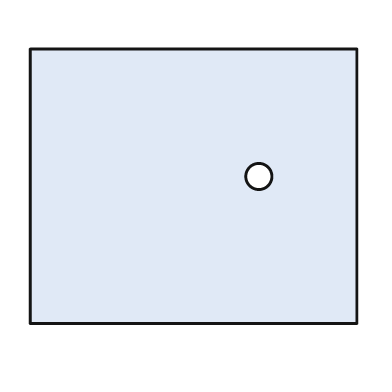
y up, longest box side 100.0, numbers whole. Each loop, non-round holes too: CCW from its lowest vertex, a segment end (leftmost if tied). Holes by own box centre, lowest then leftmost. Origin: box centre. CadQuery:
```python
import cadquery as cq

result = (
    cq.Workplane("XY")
    .moveTo(-50.0, -42.0)
    .lineTo(50.0, -42.0)
    .lineTo(50.0, 42.0)
    .lineTo(-50.0, 42.0)
    .close()
    .moveTo(20.0, 3.0)
    .circle(4.0)
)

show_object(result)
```